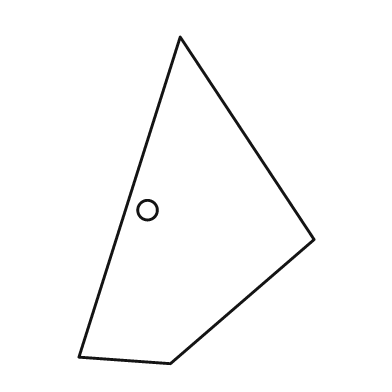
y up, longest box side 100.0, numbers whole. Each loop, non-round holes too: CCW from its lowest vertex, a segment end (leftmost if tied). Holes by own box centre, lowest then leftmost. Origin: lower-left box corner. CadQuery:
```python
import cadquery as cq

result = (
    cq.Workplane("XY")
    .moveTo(28.0, 0.0)
    .lineTo(72.0, 38.0)
    .lineTo(31.0, 100.0)
    .lineTo(0.0, 2.0)
    .close()
    .moveTo(21.0, 47.0)
    .circle(3.0)
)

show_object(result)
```